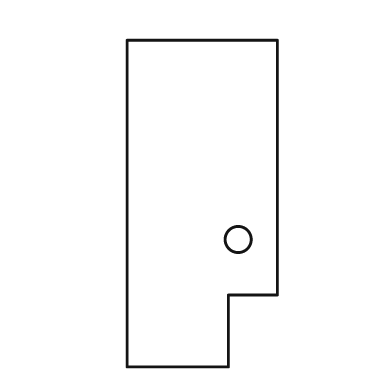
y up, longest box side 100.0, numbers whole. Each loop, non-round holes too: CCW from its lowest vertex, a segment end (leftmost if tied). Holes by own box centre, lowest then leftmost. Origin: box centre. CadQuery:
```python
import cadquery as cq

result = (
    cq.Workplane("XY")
    .moveTo(-23.0, -50.0)
    .lineTo(8.0, -50.0)
    .lineTo(8.0, -28.0)
    .lineTo(23.0, -28.0)
    .lineTo(23.0, 50.0)
    .lineTo(-23.0, 50.0)
    .close()
    .moveTo(11.0, -11.0)
    .circle(4.0)
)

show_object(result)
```